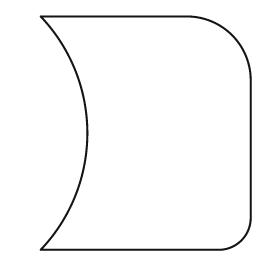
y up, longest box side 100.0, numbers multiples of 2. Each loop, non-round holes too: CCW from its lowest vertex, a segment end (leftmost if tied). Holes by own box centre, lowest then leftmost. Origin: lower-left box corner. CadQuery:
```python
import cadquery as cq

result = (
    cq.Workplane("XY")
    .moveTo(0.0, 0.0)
    .lineTo(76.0, 0.0)
    .threePointArc((86.0, 4.0), (90.0, 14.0))
    .lineTo(90.0, 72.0)
    .threePointArc((82.0, 92.0), (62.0, 100.0))
    .lineTo(0.0, 100.0)
    .threePointArc((20.0, 50.0), (0.0, 0.0))
    .close()
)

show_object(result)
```